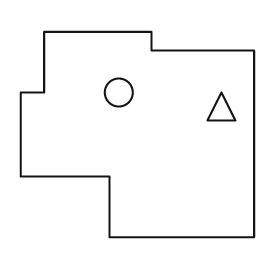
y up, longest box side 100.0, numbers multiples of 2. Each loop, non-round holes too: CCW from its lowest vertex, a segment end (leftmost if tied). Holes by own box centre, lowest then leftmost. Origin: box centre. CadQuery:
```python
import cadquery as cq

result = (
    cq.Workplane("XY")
    .moveTo(-12.0, -44.0)
    .lineTo(50.0, -44.0)
    .lineTo(50.0, 36.0)
    .lineTo(6.0, 36.0)
    .lineTo(6.0, 44.0)
    .lineTo(-40.0, 44.0)
    .lineTo(-40.0, 18.0)
    .lineTo(-50.0, 18.0)
    .lineTo(-50.0, -18.0)
    .lineTo(-12.0, -18.0)
    .close()
    .moveTo(30.0, 6.0)
    .lineTo(42.0, 6.0)
    .lineTo(36.0, 18.0)
    .close()
    .moveTo(-8.0, 18.0)
    .circle(6.0)
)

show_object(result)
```